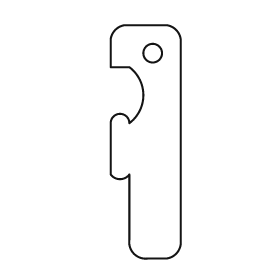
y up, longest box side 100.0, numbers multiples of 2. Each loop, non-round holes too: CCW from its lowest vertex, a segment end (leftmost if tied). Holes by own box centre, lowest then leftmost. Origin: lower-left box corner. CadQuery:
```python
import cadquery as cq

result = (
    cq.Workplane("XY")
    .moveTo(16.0, 0.0)
    .lineTo(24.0, 0.0)
    .threePointArc((28.0, 2.0), (30.0, 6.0))
    .lineTo(30.0, 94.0)
    .threePointArc((28.0, 98.0), (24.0, 100.0))
    .lineTo(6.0, 100.0)
    .threePointArc((2.0, 98.0), (0.0, 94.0))
    .lineTo(0.0, 82.0)
    .lineTo(8.0, 82.0)
    .threePointArc((14.0, 70.0), (8.0, 58.0))
    .threePointArc((4.0, 62.0), (0.0, 58.0))
    .lineTo(0.0, 36.0)
    .threePointArc((4.0, 34.0), (8.0, 36.0))
    .lineTo(8.0, 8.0)
    .threePointArc((10.0, 2.0), (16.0, 0.0))
    .close()
    .moveTo(18.0, 88.0)
    .circle(4.0)
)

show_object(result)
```